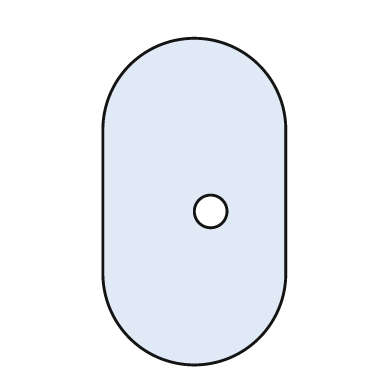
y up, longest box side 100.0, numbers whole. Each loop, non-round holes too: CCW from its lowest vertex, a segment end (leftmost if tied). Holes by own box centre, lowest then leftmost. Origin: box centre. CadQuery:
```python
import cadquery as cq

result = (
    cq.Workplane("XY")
    .moveTo(-28.0, -22.0)
    .threePointArc((0.0, -50.0), (28.0, -22.0))
    .lineTo(28.0, 22.0)
    .threePointArc((0.0, 50.0), (-28.0, 22.0))
    .close()
    .moveTo(5.0, -3.0)
    .circle(5.0)
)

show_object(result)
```